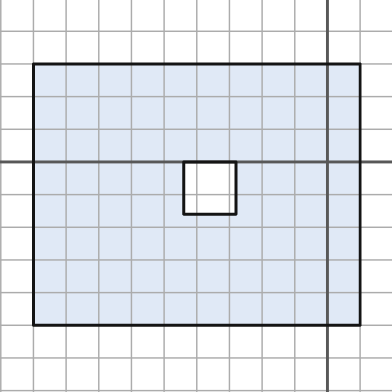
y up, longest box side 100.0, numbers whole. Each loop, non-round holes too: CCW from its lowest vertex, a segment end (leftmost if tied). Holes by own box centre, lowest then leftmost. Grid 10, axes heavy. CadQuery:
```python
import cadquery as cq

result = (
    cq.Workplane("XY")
    .moveTo(-90.0, -50.0)
    .lineTo(10.0, -50.0)
    .lineTo(10.0, 30.0)
    .lineTo(-90.0, 30.0)
    .close()
    .moveTo(-44.0, -16.0)
    .lineTo(-28.0, -16.0)
    .lineTo(-28.0, 0.0)
    .lineTo(-44.0, 0.0)
    .close()
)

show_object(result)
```